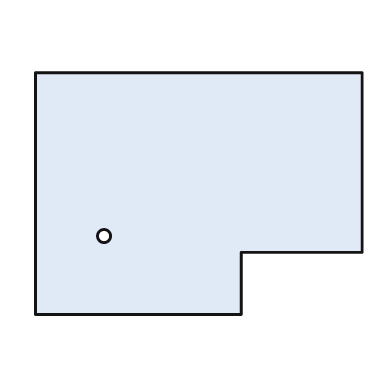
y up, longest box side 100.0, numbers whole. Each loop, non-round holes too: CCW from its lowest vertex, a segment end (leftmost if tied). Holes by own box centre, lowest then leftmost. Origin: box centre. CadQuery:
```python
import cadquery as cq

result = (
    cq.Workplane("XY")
    .moveTo(-50.0, -37.0)
    .lineTo(13.0, -37.0)
    .lineTo(13.0, -18.0)
    .lineTo(50.0, -18.0)
    .lineTo(50.0, 37.0)
    .lineTo(-50.0, 37.0)
    .close()
    .moveTo(-29.0, -13.0)
    .circle(2.0)
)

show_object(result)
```